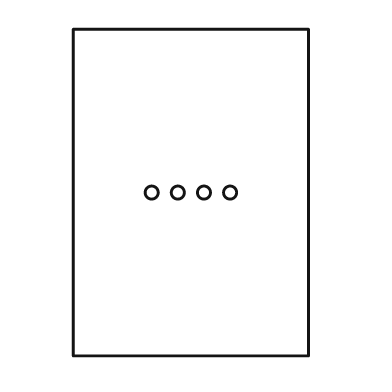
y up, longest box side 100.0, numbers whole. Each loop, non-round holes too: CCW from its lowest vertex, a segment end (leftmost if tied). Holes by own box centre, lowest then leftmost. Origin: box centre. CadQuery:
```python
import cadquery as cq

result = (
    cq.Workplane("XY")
    .moveTo(-36.0, -50.0)
    .lineTo(36.0, -50.0)
    .lineTo(36.0, 50.0)
    .lineTo(-36.0, 50.0)
    .close()
    .moveTo(-12.0, 0.0)
    .circle(2.0)
    .moveTo(-4.0, 0.0)
    .circle(2.0)
    .moveTo(4.0, 0.0)
    .circle(2.0)
    .moveTo(12.0, 0.0)
    .circle(2.0)
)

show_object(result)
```